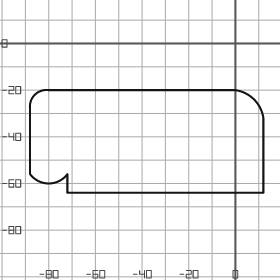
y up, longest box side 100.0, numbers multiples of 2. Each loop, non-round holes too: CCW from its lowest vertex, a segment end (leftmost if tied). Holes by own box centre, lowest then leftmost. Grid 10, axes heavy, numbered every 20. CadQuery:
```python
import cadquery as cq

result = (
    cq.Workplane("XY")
    .moveTo(-72.0, -64.0)
    .lineTo(12.0, -64.0)
    .lineTo(12.0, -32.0)
    .threePointArc((8.0, -24.0), (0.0, -20.0))
    .lineTo(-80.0, -20.0)
    .threePointArc((-86.0, -22.0), (-88.0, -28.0))
    .lineTo(-88.0, -56.0)
    .threePointArc((-80.0, -60.0), (-72.0, -56.0))
    .close()
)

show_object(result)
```